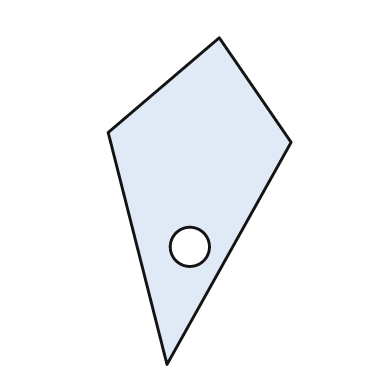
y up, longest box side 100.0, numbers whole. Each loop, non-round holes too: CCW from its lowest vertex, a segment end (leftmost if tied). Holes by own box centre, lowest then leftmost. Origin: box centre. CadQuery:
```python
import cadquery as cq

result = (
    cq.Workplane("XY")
    .moveTo(-10.0, -50.0)
    .lineTo(28.0, 18.0)
    .lineTo(6.0, 50.0)
    .lineTo(-28.0, 21.0)
    .close()
    .moveTo(-3.0, -14.0)
    .circle(6.0)
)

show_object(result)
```